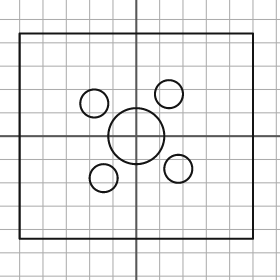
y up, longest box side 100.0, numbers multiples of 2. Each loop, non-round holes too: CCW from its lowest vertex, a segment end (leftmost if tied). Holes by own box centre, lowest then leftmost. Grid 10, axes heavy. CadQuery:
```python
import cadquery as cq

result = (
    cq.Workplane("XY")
    .moveTo(-50.0, -44.0)
    .lineTo(50.0, -44.0)
    .lineTo(50.0, 44.0)
    .lineTo(-50.0, 44.0)
    .close()
    .moveTo(-14.0, -18.0)
    .circle(6.0)
    .moveTo(18.0, -14.0)
    .circle(6.0)
    .moveTo(0.0, 0.0)
    .circle(12.0)
    .moveTo(-18.0, 14.0)
    .circle(6.0)
    .moveTo(14.0, 18.0)
    .circle(6.0)
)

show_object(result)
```